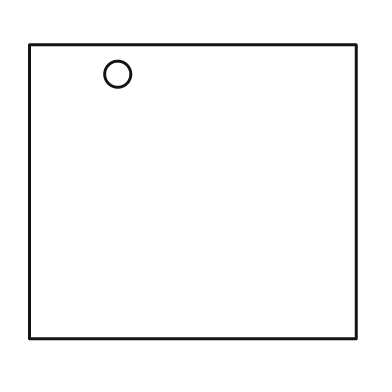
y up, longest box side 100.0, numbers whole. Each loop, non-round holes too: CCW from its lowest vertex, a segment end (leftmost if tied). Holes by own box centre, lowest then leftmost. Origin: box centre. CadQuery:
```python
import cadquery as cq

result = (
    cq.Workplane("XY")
    .moveTo(-50.0, -45.0)
    .lineTo(50.0, -45.0)
    .lineTo(50.0, 45.0)
    .lineTo(-50.0, 45.0)
    .close()
    .moveTo(-23.0, 36.0)
    .circle(4.0)
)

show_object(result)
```